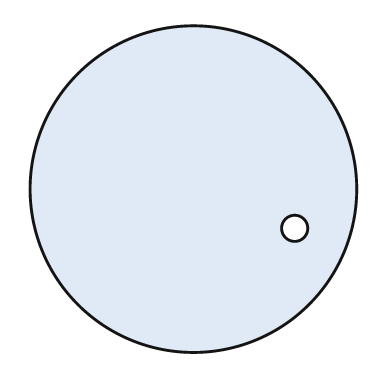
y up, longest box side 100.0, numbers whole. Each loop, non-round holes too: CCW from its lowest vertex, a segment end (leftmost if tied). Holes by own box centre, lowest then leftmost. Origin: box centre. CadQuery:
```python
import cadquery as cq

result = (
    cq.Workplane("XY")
    .moveTo(0.0, 0.0)
    .circle(50.0)
    .moveTo(31.0, -12.0)
    .circle(4.0)
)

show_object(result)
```